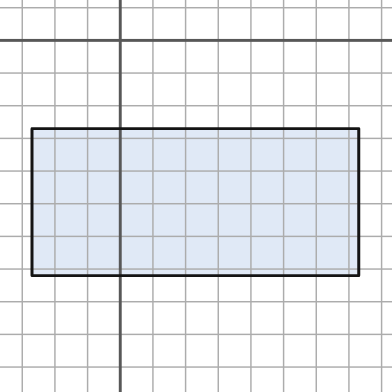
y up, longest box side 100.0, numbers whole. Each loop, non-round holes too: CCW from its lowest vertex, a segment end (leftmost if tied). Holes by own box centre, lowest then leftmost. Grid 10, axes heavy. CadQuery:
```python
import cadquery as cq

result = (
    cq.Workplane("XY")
    .moveTo(-27.0, -72.0)
    .lineTo(73.0, -72.0)
    .lineTo(73.0, -27.0)
    .lineTo(-27.0, -27.0)
    .close()
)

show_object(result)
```